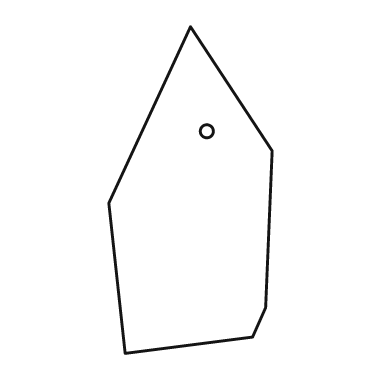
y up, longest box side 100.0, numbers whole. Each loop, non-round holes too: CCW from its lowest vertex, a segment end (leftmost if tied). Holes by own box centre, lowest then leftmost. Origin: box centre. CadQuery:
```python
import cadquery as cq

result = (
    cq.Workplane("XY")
    .moveTo(-20.0, -50.0)
    .lineTo(19.0, -45.0)
    .lineTo(23.0, -36.0)
    .lineTo(25.0, 12.0)
    .lineTo(0.0, 50.0)
    .lineTo(-25.0, -4.0)
    .close()
    .moveTo(5.0, 18.0)
    .circle(2.0)
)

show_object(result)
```